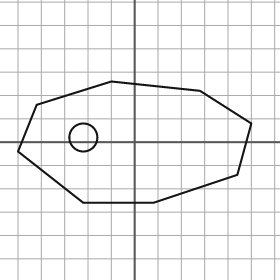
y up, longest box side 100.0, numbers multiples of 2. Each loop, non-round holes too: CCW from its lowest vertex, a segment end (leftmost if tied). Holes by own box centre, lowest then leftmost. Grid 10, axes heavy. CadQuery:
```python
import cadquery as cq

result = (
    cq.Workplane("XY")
    .moveTo(-22.0, -26.0)
    .lineTo(8.0, -26.0)
    .lineTo(44.0, -14.0)
    .lineTo(50.0, 8.0)
    .lineTo(28.0, 22.0)
    .lineTo(-10.0, 26.0)
    .lineTo(-42.0, 16.0)
    .lineTo(-50.0, -4.0)
    .close()
    .moveTo(-22.0, 2.0)
    .circle(6.0)
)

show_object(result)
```